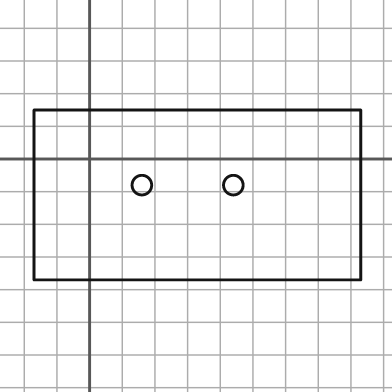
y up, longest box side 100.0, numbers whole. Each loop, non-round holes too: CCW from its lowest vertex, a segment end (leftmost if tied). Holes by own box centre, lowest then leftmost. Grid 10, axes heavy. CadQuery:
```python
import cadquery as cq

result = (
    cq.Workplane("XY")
    .moveTo(-17.0, -37.0)
    .lineTo(83.0, -37.0)
    .lineTo(83.0, 15.0)
    .lineTo(-17.0, 15.0)
    .close()
    .moveTo(16.0, -8.0)
    .circle(3.0)
    .moveTo(44.0, -8.0)
    .circle(3.0)
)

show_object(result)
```